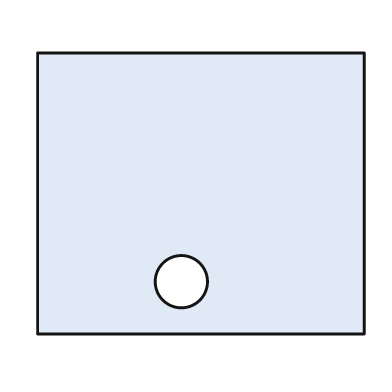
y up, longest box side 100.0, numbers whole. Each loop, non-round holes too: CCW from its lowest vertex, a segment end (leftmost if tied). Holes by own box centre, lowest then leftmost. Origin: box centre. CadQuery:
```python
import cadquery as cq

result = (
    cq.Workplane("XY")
    .moveTo(-50.0, -43.0)
    .lineTo(50.0, -43.0)
    .lineTo(50.0, 43.0)
    .lineTo(-50.0, 43.0)
    .close()
    .moveTo(-6.0, -27.0)
    .circle(8.0)
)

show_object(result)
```